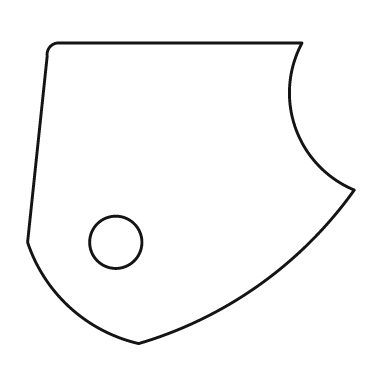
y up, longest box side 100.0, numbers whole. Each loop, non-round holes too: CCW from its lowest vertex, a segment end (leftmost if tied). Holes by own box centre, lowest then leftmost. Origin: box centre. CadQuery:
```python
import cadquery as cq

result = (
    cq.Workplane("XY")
    .moveTo(-16.0, -46.0)
    .threePointArc((21.0, -28.0), (50.0, 1.0))
    .threePointArc((32.0, 20.0), (34.0, 46.0))
    .lineTo(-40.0, 46.0)
    .threePointArc((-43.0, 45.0), (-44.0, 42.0))
    .lineTo(-50.0, -15.0)
    .threePointArc((-37.0, -35.0), (-16.0, -46.0))
    .close()
    .moveTo(-23.0, -15.0)
    .circle(8.0)
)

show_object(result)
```